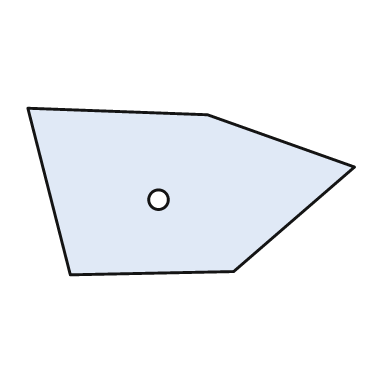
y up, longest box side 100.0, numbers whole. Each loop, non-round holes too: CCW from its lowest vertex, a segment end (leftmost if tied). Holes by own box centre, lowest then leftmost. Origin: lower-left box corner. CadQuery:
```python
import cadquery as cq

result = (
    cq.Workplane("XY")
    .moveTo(13.0, 0.0)
    .lineTo(63.0, 1.0)
    .lineTo(100.0, 33.0)
    .lineTo(55.0, 49.0)
    .lineTo(0.0, 51.0)
    .close()
    .moveTo(40.0, 23.0)
    .circle(3.0)
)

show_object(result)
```